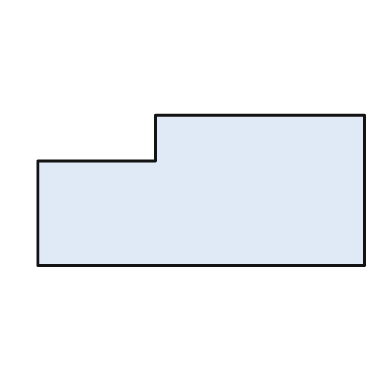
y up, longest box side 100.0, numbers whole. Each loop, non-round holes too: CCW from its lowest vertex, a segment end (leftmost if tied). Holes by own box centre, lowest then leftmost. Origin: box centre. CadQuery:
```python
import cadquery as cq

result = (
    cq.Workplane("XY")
    .moveTo(-50.0, -23.0)
    .lineTo(50.0, -23.0)
    .lineTo(50.0, 23.0)
    .lineTo(-14.0, 23.0)
    .lineTo(-14.0, 9.0)
    .lineTo(-50.0, 9.0)
    .close()
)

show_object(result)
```